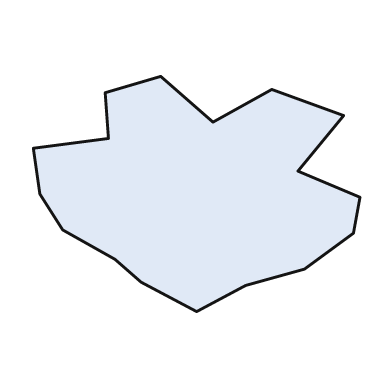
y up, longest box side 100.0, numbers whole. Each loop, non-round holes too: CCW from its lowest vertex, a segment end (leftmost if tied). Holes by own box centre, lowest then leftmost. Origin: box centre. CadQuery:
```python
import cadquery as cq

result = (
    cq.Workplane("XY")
    .moveTo(0.0, -36.0)
    .lineTo(15.0, -28.0)
    .lineTo(33.0, -23.0)
    .lineTo(48.0, -12.0)
    .lineTo(50.0, -1.0)
    .lineTo(31.0, 7.0)
    .lineTo(45.0, 24.0)
    .lineTo(23.0, 32.0)
    .lineTo(5.0, 22.0)
    .lineTo(-11.0, 36.0)
    .lineTo(-28.0, 31.0)
    .lineTo(-27.0, 17.0)
    .lineTo(-50.0, 14.0)
    .lineTo(-48.0, 0.0)
    .lineTo(-41.0, -11.0)
    .lineTo(-25.0, -20.0)
    .lineTo(-17.0, -27.0)
    .close()
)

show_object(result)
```